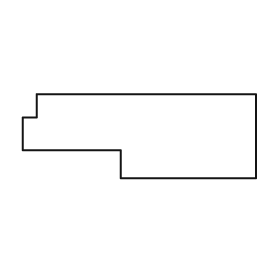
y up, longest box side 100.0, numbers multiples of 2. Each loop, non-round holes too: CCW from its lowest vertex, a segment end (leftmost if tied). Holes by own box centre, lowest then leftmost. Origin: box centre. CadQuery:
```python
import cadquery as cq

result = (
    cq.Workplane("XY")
    .moveTo(-8.0, -18.0)
    .lineTo(50.0, -18.0)
    .lineTo(50.0, 18.0)
    .lineTo(-44.0, 18.0)
    .lineTo(-44.0, 8.0)
    .lineTo(-50.0, 8.0)
    .lineTo(-50.0, -6.0)
    .lineTo(-8.0, -6.0)
    .close()
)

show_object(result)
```